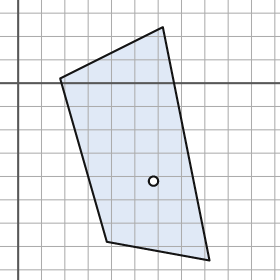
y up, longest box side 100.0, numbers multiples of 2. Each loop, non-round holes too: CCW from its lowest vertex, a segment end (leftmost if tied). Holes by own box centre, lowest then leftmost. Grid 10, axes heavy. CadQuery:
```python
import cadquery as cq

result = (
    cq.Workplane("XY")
    .moveTo(82.0, -76.0)
    .lineTo(62.0, 24.0)
    .lineTo(18.0, 2.0)
    .lineTo(38.0, -68.0)
    .close()
    .moveTo(58.0, -42.0)
    .circle(2.0)
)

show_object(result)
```